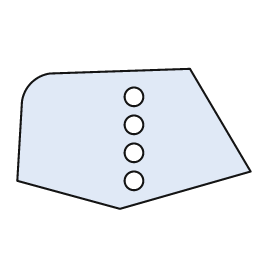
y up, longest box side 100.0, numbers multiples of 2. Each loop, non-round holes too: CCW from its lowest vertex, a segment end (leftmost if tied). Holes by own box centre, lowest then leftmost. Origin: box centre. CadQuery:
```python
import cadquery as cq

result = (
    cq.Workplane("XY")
    .moveTo(-6.0, -30.0)
    .lineTo(50.0, -14.0)
    .lineTo(24.0, 30.0)
    .lineTo(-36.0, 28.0)
    .threePointArc((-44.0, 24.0), (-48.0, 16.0))
    .lineTo(-50.0, -18.0)
    .close()
    .moveTo(0.0, -18.0)
    .circle(4.0)
    .moveTo(0.0, -6.0)
    .circle(4.0)
    .moveTo(0.0, 6.0)
    .circle(4.0)
    .moveTo(0.0, 18.0)
    .circle(4.0)
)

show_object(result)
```